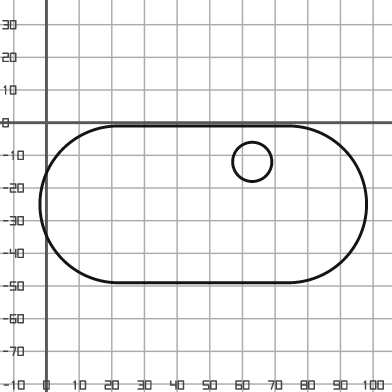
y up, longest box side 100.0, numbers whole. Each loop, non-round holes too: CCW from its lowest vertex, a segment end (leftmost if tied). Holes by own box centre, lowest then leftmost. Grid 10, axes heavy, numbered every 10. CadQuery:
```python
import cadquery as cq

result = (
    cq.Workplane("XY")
    .moveTo(22.0, -49.0)
    .lineTo(74.0, -49.0)
    .threePointArc((98.0, -25.0), (74.0, -1.0))
    .lineTo(22.0, -1.0)
    .threePointArc((-2.0, -25.0), (22.0, -49.0))
    .close()
    .moveTo(63.0, -12.0)
    .circle(6.0)
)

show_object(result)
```